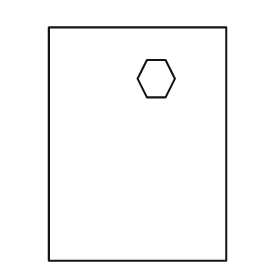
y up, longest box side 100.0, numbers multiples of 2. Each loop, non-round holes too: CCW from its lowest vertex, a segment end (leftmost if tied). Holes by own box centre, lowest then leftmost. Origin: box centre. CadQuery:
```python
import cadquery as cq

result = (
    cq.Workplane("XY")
    .moveTo(-38.0, -50.0)
    .lineTo(38.0, -50.0)
    .lineTo(38.0, 50.0)
    .lineTo(-38.0, 50.0)
    .close()
    .moveTo(4.0, 20.0)
    .lineTo(12.0, 20.0)
    .lineTo(16.0, 28.0)
    .lineTo(12.0, 36.0)
    .lineTo(4.0, 36.0)
    .lineTo(0.0, 28.0)
    .close()
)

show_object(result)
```